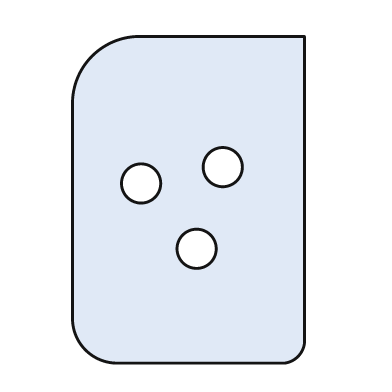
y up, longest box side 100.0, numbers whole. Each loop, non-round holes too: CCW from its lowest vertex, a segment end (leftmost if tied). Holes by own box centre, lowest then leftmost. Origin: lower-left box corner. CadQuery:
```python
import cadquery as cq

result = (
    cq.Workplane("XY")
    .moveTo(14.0, 0.0)
    .lineTo(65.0, 0.0)
    .threePointArc((69.0, 2.0), (71.0, 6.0))
    .lineTo(71.0, 100.0)
    .lineTo(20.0, 100.0)
    .threePointArc((6.0, 94.0), (0.0, 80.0))
    .lineTo(0.0, 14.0)
    .threePointArc((4.0, 4.0), (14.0, 0.0))
    .close()
    .moveTo(38.0, 35.0)
    .circle(6.0)
    .moveTo(21.0, 55.0)
    .circle(6.0)
    .moveTo(46.0, 60.0)
    .circle(6.0)
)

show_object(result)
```